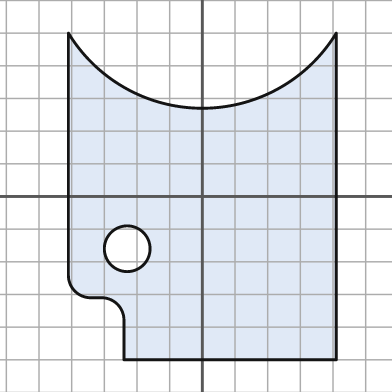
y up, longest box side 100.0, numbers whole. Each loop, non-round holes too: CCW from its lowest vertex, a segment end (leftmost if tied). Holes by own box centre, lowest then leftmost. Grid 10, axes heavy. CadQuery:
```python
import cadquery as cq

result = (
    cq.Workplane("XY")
    .moveTo(-24.0, -50.0)
    .lineTo(41.0, -50.0)
    .lineTo(41.0, 50.0)
    .threePointArc((0.0, 27.0), (-41.0, 50.0))
    .lineTo(-41.0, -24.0)
    .threePointArc((-39.0, -29.0), (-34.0, -31.0))
    .lineTo(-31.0, -31.0)
    .threePointArc((-26.0, -33.0), (-24.0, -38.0))
    .close()
    .moveTo(-23.0, -16.0)
    .circle(7.0)
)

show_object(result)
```